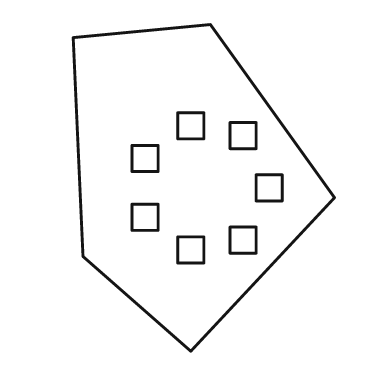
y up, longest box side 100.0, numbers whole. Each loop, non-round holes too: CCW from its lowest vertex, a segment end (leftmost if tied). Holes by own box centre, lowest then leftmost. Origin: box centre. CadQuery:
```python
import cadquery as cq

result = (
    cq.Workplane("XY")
    .moveTo(-4.0, -50.0)
    .lineTo(40.0, -3.0)
    .lineTo(2.0, 50.0)
    .lineTo(-40.0, 46.0)
    .lineTo(-37.0, -21.0)
    .close()
    .moveTo(-8.0, -23.0)
    .lineTo(0.0, -23.0)
    .lineTo(0.0, -15.0)
    .lineTo(-8.0, -15.0)
    .close()
    .moveTo(8.0, -20.0)
    .lineTo(16.0, -20.0)
    .lineTo(16.0, -12.0)
    .lineTo(8.0, -12.0)
    .close()
    .moveTo(-22.0, -13.0)
    .lineTo(-14.0, -13.0)
    .lineTo(-14.0, -5.0)
    .lineTo(-22.0, -5.0)
    .close()
    .moveTo(16.0, -4.0)
    .lineTo(24.0, -4.0)
    .lineTo(24.0, 4.0)
    .lineTo(16.0, 4.0)
    .close()
    .moveTo(-22.0, 5.0)
    .lineTo(-14.0, 5.0)
    .lineTo(-14.0, 13.0)
    .lineTo(-22.0, 13.0)
    .close()
    .moveTo(8.0, 12.0)
    .lineTo(16.0, 12.0)
    .lineTo(16.0, 20.0)
    .lineTo(8.0, 20.0)
    .close()
    .moveTo(-8.0, 15.0)
    .lineTo(0.0, 15.0)
    .lineTo(0.0, 23.0)
    .lineTo(-8.0, 23.0)
    .close()
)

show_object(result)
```